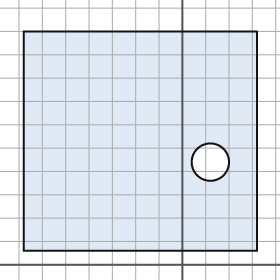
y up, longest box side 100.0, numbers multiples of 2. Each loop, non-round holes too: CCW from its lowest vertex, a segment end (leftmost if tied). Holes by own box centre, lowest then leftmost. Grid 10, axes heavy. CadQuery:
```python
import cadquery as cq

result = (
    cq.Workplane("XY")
    .moveTo(-68.0, 6.0)
    .lineTo(32.0, 6.0)
    .lineTo(32.0, 100.0)
    .lineTo(-68.0, 100.0)
    .close()
    .moveTo(12.0, 44.0)
    .circle(8.0)
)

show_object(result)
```